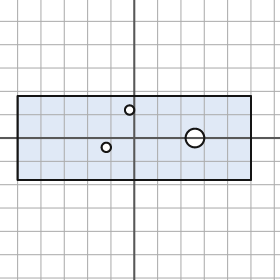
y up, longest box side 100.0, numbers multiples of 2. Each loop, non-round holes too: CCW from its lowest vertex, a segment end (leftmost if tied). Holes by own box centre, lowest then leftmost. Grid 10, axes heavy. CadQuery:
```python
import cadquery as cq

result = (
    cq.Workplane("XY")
    .moveTo(-50.0, -18.0)
    .lineTo(50.0, -18.0)
    .lineTo(50.0, 18.0)
    .lineTo(-50.0, 18.0)
    .close()
    .moveTo(-12.0, -4.0)
    .circle(2.0)
    .moveTo(26.0, 0.0)
    .circle(4.0)
    .moveTo(-2.0, 12.0)
    .circle(2.0)
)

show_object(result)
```